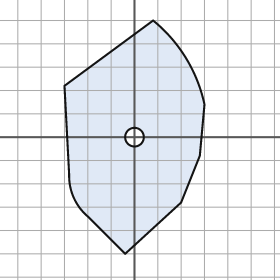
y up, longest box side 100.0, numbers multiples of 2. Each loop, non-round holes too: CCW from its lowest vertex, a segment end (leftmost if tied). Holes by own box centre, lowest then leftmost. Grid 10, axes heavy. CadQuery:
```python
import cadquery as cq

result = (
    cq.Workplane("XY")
    .moveTo(-4.0, -50.0)
    .lineTo(20.0, -28.0)
    .lineTo(28.0, -8.0)
    .lineTo(30.0, 14.0)
    .threePointArc((22.0, 34.0), (8.0, 50.0))
    .lineTo(-30.0, 22.0)
    .lineTo(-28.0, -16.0)
    .threePointArc((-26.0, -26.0), (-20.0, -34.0))
    .close()
    .moveTo(0.0, 0.0)
    .circle(4.0)
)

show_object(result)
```